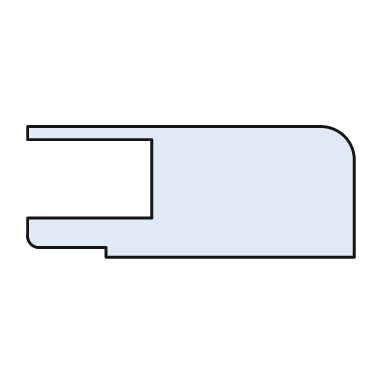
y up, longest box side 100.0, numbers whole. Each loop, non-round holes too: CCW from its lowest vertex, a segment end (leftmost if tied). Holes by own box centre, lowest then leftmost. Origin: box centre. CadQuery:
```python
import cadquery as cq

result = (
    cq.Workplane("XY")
    .moveTo(-26.0, -20.0)
    .lineTo(50.0, -20.0)
    .lineTo(50.0, 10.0)
    .threePointArc((47.0, 17.0), (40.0, 20.0))
    .lineTo(-50.0, 20.0)
    .lineTo(-50.0, 16.0)
    .lineTo(-12.0, 16.0)
    .lineTo(-12.0, -8.0)
    .lineTo(-50.0, -8.0)
    .lineTo(-50.0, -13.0)
    .threePointArc((-49.0, -16.0), (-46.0, -17.0))
    .lineTo(-26.0, -17.0)
    .close()
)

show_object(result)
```